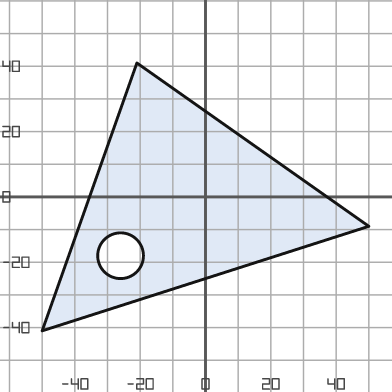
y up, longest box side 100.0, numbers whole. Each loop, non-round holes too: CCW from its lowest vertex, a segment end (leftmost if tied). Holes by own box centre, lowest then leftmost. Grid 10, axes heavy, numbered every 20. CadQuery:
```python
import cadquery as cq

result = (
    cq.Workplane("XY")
    .moveTo(-50.0, -41.0)
    .lineTo(50.0, -9.0)
    .lineTo(-21.0, 41.0)
    .close()
    .moveTo(-26.0, -18.0)
    .circle(7.0)
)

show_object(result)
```